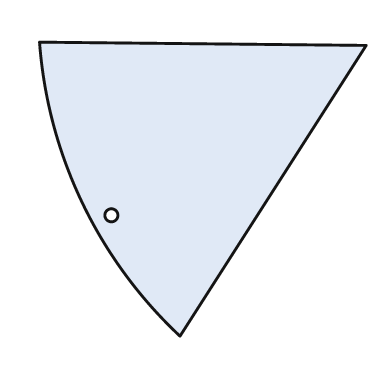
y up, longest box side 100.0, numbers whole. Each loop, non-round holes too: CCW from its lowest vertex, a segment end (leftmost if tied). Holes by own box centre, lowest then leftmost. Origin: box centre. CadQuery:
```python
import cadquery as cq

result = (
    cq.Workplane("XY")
    .moveTo(-7.0, -45.0)
    .lineTo(50.0, 44.0)
    .lineTo(-50.0, 45.0)
    .threePointArc((-37.0, -4.0), (-7.0, -45.0))
    .close()
    .moveTo(-28.0, -8.0)
    .circle(2.0)
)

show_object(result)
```